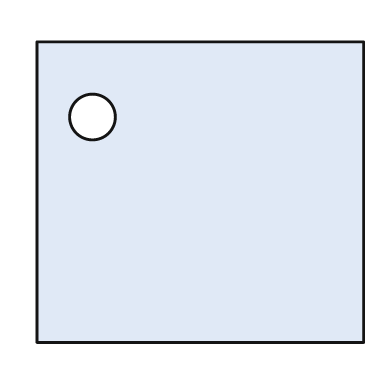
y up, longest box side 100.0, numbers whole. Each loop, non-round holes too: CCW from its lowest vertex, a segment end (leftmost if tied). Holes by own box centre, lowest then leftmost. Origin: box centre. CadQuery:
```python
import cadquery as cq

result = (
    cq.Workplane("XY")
    .moveTo(-50.0, -46.0)
    .lineTo(50.0, -46.0)
    .lineTo(50.0, 46.0)
    .lineTo(-50.0, 46.0)
    .close()
    .moveTo(-33.0, 23.0)
    .circle(7.0)
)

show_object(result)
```